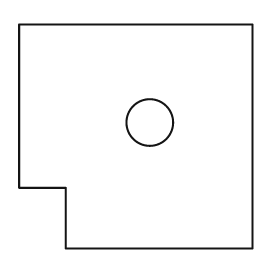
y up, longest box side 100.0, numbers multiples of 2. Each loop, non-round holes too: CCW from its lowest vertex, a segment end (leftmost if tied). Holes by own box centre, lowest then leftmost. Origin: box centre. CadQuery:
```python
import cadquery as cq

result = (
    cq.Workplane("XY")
    .moveTo(-30.0, -48.0)
    .lineTo(50.0, -48.0)
    .lineTo(50.0, 48.0)
    .lineTo(-50.0, 48.0)
    .lineTo(-50.0, -22.0)
    .lineTo(-30.0, -22.0)
    .close()
    .moveTo(6.0, 6.0)
    .circle(10.0)
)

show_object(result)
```